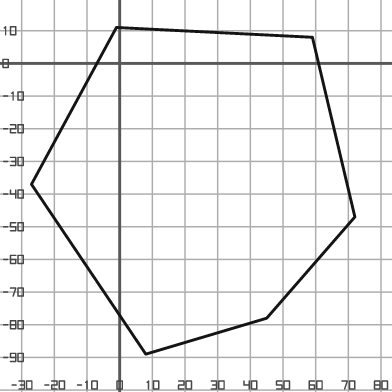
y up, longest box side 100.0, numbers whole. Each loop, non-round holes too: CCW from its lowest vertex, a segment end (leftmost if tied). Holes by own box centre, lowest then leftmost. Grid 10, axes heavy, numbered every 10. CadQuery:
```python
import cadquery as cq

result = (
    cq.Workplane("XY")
    .moveTo(8.0, -89.0)
    .lineTo(45.0, -78.0)
    .lineTo(72.0, -47.0)
    .lineTo(59.0, 8.0)
    .lineTo(-1.0, 11.0)
    .lineTo(-27.0, -37.0)
    .close()
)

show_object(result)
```